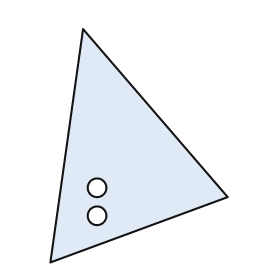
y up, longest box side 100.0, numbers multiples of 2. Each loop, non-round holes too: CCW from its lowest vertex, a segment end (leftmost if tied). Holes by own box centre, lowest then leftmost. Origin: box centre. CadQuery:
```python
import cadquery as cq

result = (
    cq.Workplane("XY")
    .moveTo(-38.0, -50.0)
    .lineTo(38.0, -22.0)
    .lineTo(-24.0, 50.0)
    .close()
    .moveTo(-18.0, -30.0)
    .circle(4.0)
    .moveTo(-18.0, -18.0)
    .circle(4.0)
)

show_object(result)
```